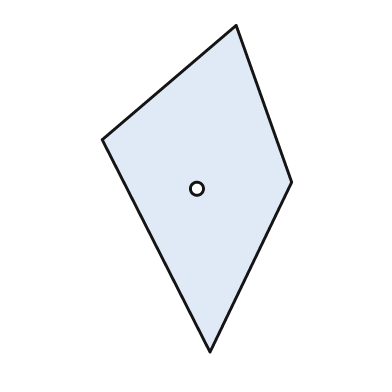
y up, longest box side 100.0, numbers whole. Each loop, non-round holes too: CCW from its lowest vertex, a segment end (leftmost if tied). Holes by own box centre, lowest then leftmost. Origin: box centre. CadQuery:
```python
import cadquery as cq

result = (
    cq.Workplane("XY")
    .moveTo(4.0, -50.0)
    .lineTo(29.0, 2.0)
    .lineTo(12.0, 50.0)
    .lineTo(-29.0, 15.0)
    .close()
    .moveTo(0.0, 0.0)
    .circle(2.0)
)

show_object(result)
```